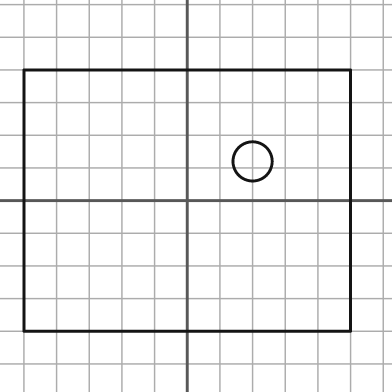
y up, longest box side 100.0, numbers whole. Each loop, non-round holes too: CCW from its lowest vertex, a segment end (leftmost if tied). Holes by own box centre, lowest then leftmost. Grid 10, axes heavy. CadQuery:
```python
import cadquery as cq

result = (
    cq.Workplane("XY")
    .moveTo(-50.0, -40.0)
    .lineTo(50.0, -40.0)
    .lineTo(50.0, 40.0)
    .lineTo(-50.0, 40.0)
    .close()
    .moveTo(20.0, 12.0)
    .circle(6.0)
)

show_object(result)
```